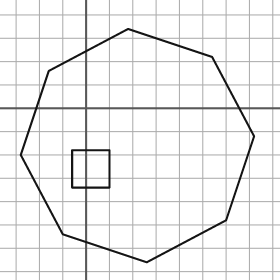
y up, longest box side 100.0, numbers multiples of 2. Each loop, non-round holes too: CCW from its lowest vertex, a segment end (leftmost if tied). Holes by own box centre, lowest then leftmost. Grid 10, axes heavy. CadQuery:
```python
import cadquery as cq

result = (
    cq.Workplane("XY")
    .moveTo(26.0, -66.0)
    .lineTo(60.0, -48.0)
    .lineTo(72.0, -12.0)
    .lineTo(54.0, 22.0)
    .lineTo(18.0, 34.0)
    .lineTo(-16.0, 16.0)
    .lineTo(-28.0, -20.0)
    .lineTo(-10.0, -54.0)
    .close()
    .moveTo(-6.0, -34.0)
    .lineTo(10.0, -34.0)
    .lineTo(10.0, -18.0)
    .lineTo(-6.0, -18.0)
    .close()
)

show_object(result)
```